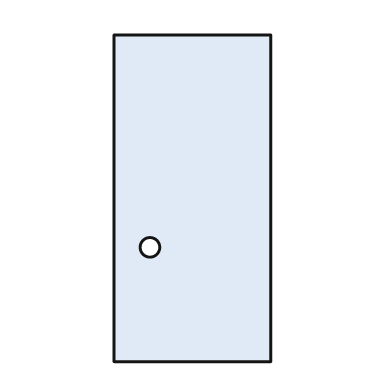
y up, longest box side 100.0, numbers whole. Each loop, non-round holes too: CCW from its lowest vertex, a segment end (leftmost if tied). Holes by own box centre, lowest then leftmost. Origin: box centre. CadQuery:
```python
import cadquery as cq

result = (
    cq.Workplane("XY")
    .moveTo(-24.0, -50.0)
    .lineTo(24.0, -50.0)
    .lineTo(24.0, 50.0)
    .lineTo(-24.0, 50.0)
    .close()
    .moveTo(-13.0, -15.0)
    .circle(3.0)
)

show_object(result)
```